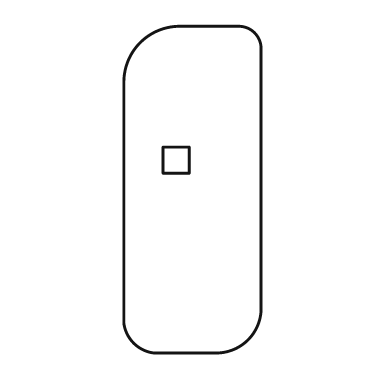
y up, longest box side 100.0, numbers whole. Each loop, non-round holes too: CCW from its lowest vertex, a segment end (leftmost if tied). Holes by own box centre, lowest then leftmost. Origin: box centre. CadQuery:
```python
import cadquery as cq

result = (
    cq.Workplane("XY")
    .moveTo(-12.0, -50.0)
    .lineTo(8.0, -50.0)
    .threePointArc((17.0, -46.0), (21.0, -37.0))
    .lineTo(21.0, 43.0)
    .threePointArc((19.0, 48.0), (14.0, 50.0))
    .lineTo(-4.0, 50.0)
    .threePointArc((-16.0, 45.0), (-21.0, 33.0))
    .lineTo(-21.0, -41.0)
    .threePointArc((-18.0, -47.0), (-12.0, -50.0))
    .close()
    .moveTo(-9.0, 5.0)
    .lineTo(-1.0, 5.0)
    .lineTo(-1.0, 13.0)
    .lineTo(-9.0, 13.0)
    .close()
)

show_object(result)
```